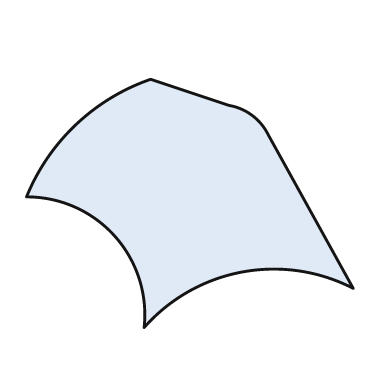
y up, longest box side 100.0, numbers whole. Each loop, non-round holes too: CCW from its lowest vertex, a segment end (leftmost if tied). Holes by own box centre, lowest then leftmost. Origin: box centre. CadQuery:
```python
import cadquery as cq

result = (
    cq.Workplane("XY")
    .moveTo(-14.0, -38.0)
    .threePointArc((16.0, -21.0), (50.0, -26.0))
    .lineTo(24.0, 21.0)
    .threePointArc((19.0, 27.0), (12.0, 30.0))
    .lineTo(-12.0, 38.0)
    .threePointArc((-35.0, 24.0), (-50.0, 2.0))
    .threePointArc((-23.0, -10.0), (-14.0, -38.0))
    .close()
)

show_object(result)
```